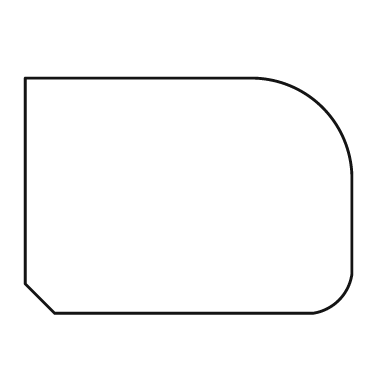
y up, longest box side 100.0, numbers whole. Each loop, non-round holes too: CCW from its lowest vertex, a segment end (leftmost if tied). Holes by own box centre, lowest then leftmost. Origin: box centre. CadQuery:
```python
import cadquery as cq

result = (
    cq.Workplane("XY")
    .moveTo(-41.0, -36.0)
    .lineTo(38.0, -36.0)
    .threePointArc((46.0, -32.0), (50.0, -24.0))
    .lineTo(50.0, 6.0)
    .threePointArc((41.0, 27.0), (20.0, 36.0))
    .lineTo(-50.0, 36.0)
    .lineTo(-50.0, -27.0)
    .close()
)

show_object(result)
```